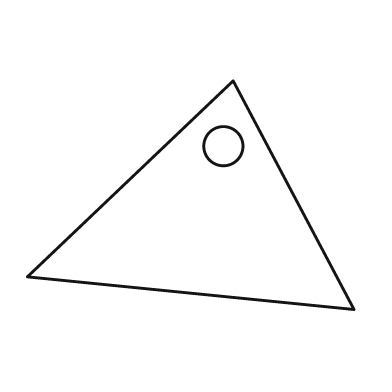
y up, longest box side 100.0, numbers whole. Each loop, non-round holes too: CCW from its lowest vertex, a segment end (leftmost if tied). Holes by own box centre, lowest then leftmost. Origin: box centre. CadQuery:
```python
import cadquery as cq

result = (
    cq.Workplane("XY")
    .moveTo(50.0, -35.0)
    .lineTo(13.0, 35.0)
    .lineTo(-50.0, -25.0)
    .close()
    .moveTo(10.0, 15.0)
    .circle(6.0)
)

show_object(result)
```